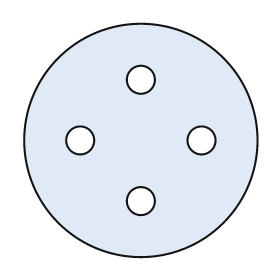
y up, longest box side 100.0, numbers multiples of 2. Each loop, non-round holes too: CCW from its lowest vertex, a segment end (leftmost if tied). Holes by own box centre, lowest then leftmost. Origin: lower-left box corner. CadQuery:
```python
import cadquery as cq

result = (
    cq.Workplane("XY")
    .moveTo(50.0, 50.0)
    .circle(50.0)
    .moveTo(50.0, 24.0)
    .circle(6.0)
    .moveTo(24.0, 50.0)
    .circle(6.0)
    .moveTo(76.0, 50.0)
    .circle(6.0)
    .moveTo(50.0, 76.0)
    .circle(6.0)
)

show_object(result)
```